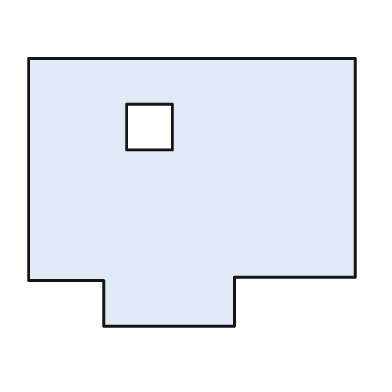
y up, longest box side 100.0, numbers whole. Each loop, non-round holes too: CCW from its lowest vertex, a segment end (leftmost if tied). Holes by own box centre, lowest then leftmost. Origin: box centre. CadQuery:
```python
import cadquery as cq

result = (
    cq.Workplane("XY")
    .moveTo(-27.0, -41.0)
    .lineTo(13.0, -41.0)
    .lineTo(13.0, -26.0)
    .lineTo(50.0, -26.0)
    .lineTo(50.0, 41.0)
    .lineTo(-50.0, 41.0)
    .lineTo(-50.0, -27.0)
    .lineTo(-27.0, -27.0)
    .close()
    .moveTo(-20.0, 13.0)
    .lineTo(-6.0, 13.0)
    .lineTo(-6.0, 27.0)
    .lineTo(-20.0, 27.0)
    .close()
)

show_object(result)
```